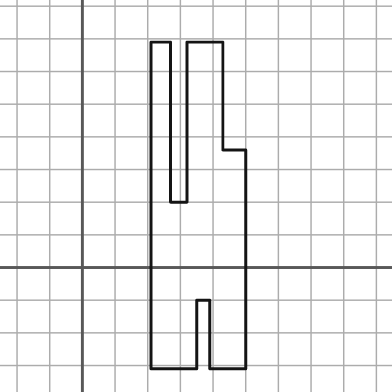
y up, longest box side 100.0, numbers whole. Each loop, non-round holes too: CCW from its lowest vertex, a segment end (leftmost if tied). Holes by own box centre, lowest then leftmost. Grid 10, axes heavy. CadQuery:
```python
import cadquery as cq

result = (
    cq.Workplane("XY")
    .moveTo(21.0, -31.0)
    .lineTo(35.0, -31.0)
    .lineTo(35.0, -10.0)
    .lineTo(39.0, -10.0)
    .lineTo(39.0, -31.0)
    .lineTo(50.0, -31.0)
    .lineTo(50.0, 36.0)
    .lineTo(43.0, 36.0)
    .lineTo(43.0, 69.0)
    .lineTo(32.0, 69.0)
    .lineTo(32.0, 20.0)
    .lineTo(27.0, 20.0)
    .lineTo(27.0, 69.0)
    .lineTo(21.0, 69.0)
    .close()
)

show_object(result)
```